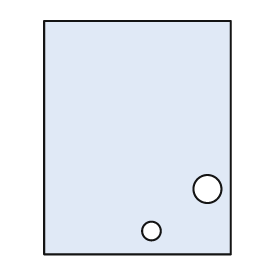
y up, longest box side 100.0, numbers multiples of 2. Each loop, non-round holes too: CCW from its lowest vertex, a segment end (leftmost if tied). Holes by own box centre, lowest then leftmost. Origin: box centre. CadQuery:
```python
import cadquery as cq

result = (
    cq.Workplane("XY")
    .moveTo(-40.0, -50.0)
    .lineTo(40.0, -50.0)
    .lineTo(40.0, 50.0)
    .lineTo(-40.0, 50.0)
    .close()
    .moveTo(6.0, -40.0)
    .circle(4.0)
    .moveTo(30.0, -22.0)
    .circle(6.0)
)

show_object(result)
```